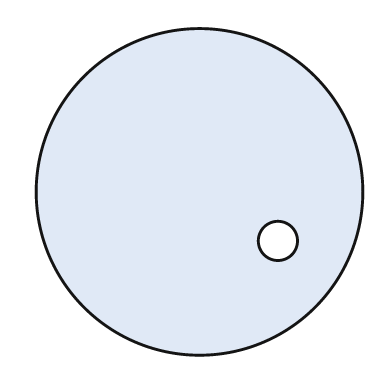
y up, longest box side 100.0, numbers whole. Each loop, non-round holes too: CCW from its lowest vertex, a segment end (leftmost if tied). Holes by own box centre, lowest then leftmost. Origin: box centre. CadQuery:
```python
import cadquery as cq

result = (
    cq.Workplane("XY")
    .moveTo(0.0, 0.0)
    .circle(50.0)
    .moveTo(24.0, -15.0)
    .circle(6.0)
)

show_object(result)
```